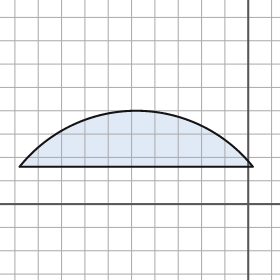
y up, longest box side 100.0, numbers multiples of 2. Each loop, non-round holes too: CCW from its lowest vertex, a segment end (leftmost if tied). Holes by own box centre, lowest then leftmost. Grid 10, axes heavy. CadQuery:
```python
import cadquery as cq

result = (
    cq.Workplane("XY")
    .moveTo(-98.0, 16.0)
    .lineTo(2.0, 16.0)
    .threePointArc((-48.0, 40.0), (-98.0, 16.0))
    .close()
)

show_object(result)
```